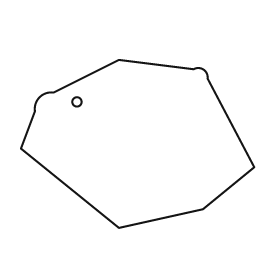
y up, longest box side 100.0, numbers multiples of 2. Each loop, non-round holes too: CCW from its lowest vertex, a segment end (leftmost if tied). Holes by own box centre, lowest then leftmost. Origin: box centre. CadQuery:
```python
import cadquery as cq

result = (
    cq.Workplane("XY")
    .moveTo(-8.0, -36.0)
    .lineTo(28.0, -28.0)
    .lineTo(50.0, -10.0)
    .lineTo(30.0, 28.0)
    .threePointArc((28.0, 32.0), (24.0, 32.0))
    .lineTo(-8.0, 36.0)
    .lineTo(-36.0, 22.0)
    .threePointArc((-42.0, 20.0), (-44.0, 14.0))
    .lineTo(-50.0, -2.0)
    .close()
    .moveTo(-26.0, 18.0)
    .circle(2.0)
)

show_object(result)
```